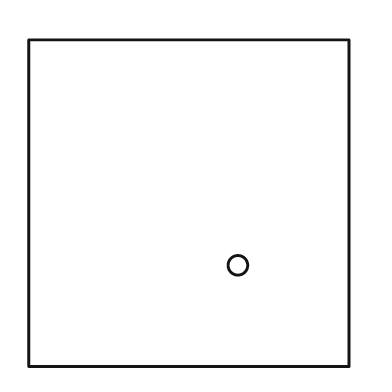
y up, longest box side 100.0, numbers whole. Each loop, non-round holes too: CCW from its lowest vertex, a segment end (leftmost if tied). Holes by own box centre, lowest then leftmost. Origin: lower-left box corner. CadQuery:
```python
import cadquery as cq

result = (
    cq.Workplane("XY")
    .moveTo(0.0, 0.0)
    .lineTo(98.0, 0.0)
    .lineTo(98.0, 100.0)
    .lineTo(0.0, 100.0)
    .close()
    .moveTo(64.0, 31.0)
    .circle(3.0)
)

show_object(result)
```